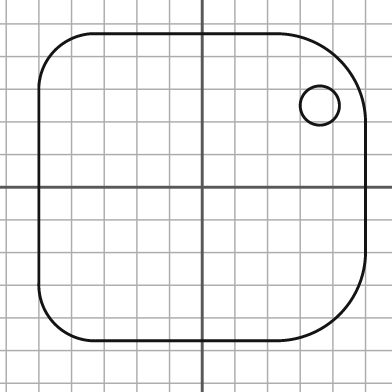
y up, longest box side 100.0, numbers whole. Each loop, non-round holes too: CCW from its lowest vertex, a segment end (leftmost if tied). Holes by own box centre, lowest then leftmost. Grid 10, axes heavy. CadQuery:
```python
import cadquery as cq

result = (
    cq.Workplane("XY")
    .moveTo(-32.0, -47.0)
    .lineTo(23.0, -47.0)
    .threePointArc((42.0, -39.0), (50.0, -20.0))
    .lineTo(50.0, 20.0)
    .threePointArc((42.0, 39.0), (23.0, 47.0))
    .lineTo(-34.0, 47.0)
    .threePointArc((-45.0, 42.0), (-50.0, 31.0))
    .lineTo(-50.0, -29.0)
    .threePointArc((-45.0, -42.0), (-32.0, -47.0))
    .close()
    .moveTo(36.0, 25.0)
    .circle(6.0)
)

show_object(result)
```